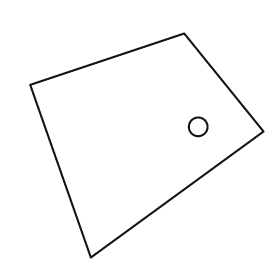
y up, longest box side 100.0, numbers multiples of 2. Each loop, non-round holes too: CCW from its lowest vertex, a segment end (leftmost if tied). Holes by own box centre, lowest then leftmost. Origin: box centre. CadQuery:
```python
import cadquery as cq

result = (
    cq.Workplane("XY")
    .moveTo(-24.0, -48.0)
    .lineTo(50.0, 6.0)
    .lineTo(16.0, 48.0)
    .lineTo(-50.0, 26.0)
    .close()
    .moveTo(22.0, 8.0)
    .circle(4.0)
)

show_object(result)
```